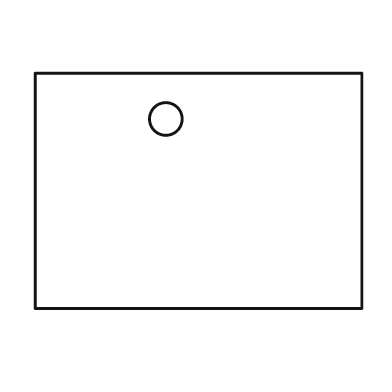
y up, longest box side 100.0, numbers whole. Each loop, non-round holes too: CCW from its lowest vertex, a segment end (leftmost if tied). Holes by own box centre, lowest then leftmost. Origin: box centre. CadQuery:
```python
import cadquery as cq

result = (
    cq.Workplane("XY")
    .moveTo(-50.0, -36.0)
    .lineTo(50.0, -36.0)
    .lineTo(50.0, 36.0)
    .lineTo(-50.0, 36.0)
    .close()
    .moveTo(-10.0, 22.0)
    .circle(5.0)
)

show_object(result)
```